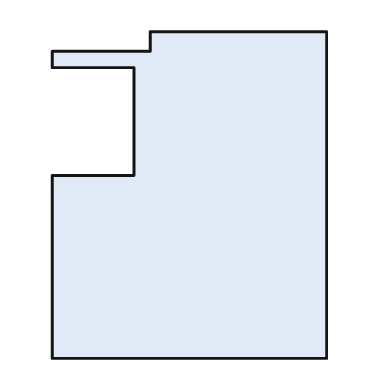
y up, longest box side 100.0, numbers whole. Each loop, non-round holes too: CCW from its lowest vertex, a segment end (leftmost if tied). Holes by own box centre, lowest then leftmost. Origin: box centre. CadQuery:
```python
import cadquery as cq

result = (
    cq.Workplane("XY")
    .moveTo(-42.0, -50.0)
    .lineTo(42.0, -50.0)
    .lineTo(42.0, 50.0)
    .lineTo(-12.0, 50.0)
    .lineTo(-12.0, 44.0)
    .lineTo(-42.0, 44.0)
    .lineTo(-42.0, 39.0)
    .lineTo(-17.0, 39.0)
    .lineTo(-17.0, 6.0)
    .lineTo(-42.0, 6.0)
    .close()
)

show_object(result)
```